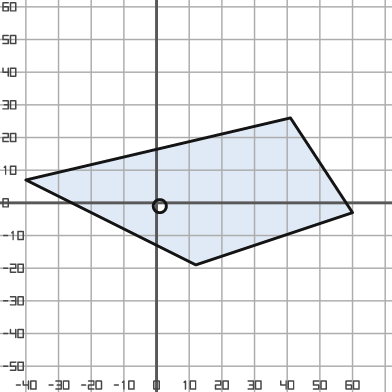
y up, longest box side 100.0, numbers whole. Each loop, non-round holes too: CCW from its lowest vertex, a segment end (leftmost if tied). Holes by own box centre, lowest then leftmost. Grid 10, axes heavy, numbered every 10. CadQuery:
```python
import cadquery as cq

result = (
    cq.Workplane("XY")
    .moveTo(12.0, -19.0)
    .lineTo(60.0, -3.0)
    .lineTo(41.0, 26.0)
    .lineTo(-40.0, 7.0)
    .close()
    .moveTo(1.0, -1.0)
    .circle(2.0)
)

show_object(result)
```